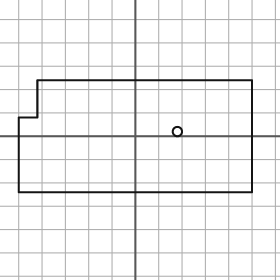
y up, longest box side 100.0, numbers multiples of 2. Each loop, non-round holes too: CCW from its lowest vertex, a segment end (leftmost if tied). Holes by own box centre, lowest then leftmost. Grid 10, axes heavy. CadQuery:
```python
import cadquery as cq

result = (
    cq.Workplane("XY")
    .moveTo(-50.0, -24.0)
    .lineTo(50.0, -24.0)
    .lineTo(50.0, 24.0)
    .lineTo(-42.0, 24.0)
    .lineTo(-42.0, 8.0)
    .lineTo(-50.0, 8.0)
    .close()
    .moveTo(18.0, 2.0)
    .circle(2.0)
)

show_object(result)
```